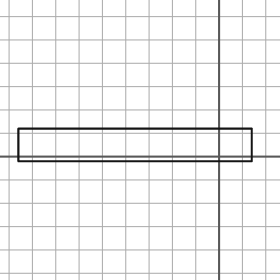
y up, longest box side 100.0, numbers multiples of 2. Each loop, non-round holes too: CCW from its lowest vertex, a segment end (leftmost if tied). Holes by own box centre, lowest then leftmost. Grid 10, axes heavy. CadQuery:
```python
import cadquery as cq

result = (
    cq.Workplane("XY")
    .moveTo(-86.0, -2.0)
    .lineTo(14.0, -2.0)
    .lineTo(14.0, 12.0)
    .lineTo(-86.0, 12.0)
    .close()
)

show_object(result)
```